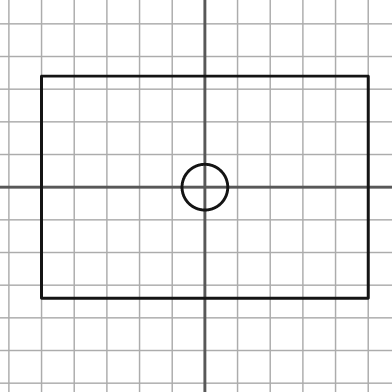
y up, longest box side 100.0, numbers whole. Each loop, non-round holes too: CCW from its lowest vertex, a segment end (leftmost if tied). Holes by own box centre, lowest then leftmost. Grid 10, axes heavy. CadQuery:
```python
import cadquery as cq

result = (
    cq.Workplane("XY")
    .moveTo(-50.0, -34.0)
    .lineTo(50.0, -34.0)
    .lineTo(50.0, 34.0)
    .lineTo(-50.0, 34.0)
    .close()
    .moveTo(0.0, 0.0)
    .circle(7.0)
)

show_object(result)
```